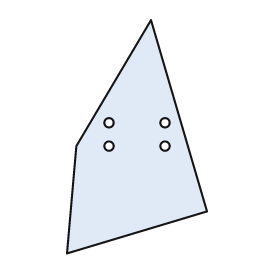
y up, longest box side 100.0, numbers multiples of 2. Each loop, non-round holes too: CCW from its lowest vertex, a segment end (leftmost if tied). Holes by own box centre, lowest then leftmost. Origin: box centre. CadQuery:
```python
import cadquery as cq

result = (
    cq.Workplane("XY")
    .moveTo(-30.0, -50.0)
    .lineTo(30.0, -32.0)
    .lineTo(6.0, 50.0)
    .lineTo(-26.0, -4.0)
    .close()
    .moveTo(-12.0, -4.0)
    .circle(2.0)
    .moveTo(12.0, -4.0)
    .circle(2.0)
    .moveTo(-12.0, 6.0)
    .circle(2.0)
    .moveTo(12.0, 6.0)
    .circle(2.0)
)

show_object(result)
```